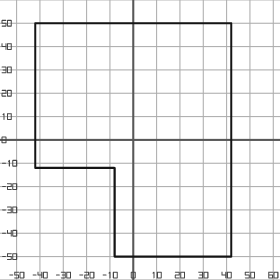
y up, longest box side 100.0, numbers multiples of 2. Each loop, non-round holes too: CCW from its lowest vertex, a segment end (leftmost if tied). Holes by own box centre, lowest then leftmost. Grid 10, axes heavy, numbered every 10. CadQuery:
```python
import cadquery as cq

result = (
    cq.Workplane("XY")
    .moveTo(-8.0, -50.0)
    .lineTo(42.0, -50.0)
    .lineTo(42.0, 50.0)
    .lineTo(-42.0, 50.0)
    .lineTo(-42.0, -12.0)
    .lineTo(-8.0, -12.0)
    .close()
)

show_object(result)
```